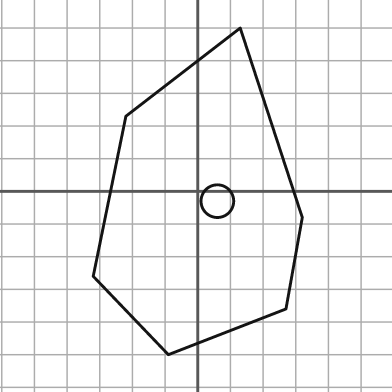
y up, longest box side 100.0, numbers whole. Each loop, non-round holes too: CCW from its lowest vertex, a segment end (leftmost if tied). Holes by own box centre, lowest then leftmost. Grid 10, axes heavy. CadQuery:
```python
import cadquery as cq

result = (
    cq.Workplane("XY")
    .moveTo(-9.0, -50.0)
    .lineTo(27.0, -36.0)
    .lineTo(32.0, -8.0)
    .lineTo(13.0, 50.0)
    .lineTo(-22.0, 23.0)
    .lineTo(-32.0, -26.0)
    .close()
    .moveTo(6.0, -3.0)
    .circle(5.0)
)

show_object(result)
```